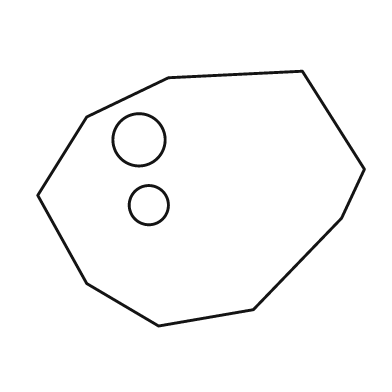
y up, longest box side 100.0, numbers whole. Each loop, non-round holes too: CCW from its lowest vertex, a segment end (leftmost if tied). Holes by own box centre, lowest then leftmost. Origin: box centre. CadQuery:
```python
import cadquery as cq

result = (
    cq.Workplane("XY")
    .moveTo(-13.0, -39.0)
    .lineTo(16.0, -34.0)
    .lineTo(43.0, -6.0)
    .lineTo(50.0, 9.0)
    .lineTo(31.0, 39.0)
    .lineTo(-10.0, 37.0)
    .lineTo(-35.0, 25.0)
    .lineTo(-50.0, 1.0)
    .lineTo(-35.0, -26.0)
    .close()
    .moveTo(-16.0, -2.0)
    .circle(6.0)
    .moveTo(-19.0, 18.0)
    .circle(8.0)
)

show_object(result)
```